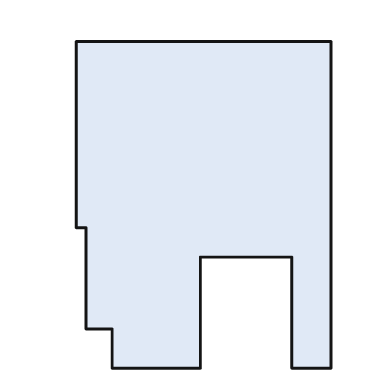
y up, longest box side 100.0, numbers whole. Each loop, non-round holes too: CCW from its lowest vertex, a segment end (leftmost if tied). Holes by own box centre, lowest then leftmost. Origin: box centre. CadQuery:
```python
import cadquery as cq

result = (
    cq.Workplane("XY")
    .moveTo(-28.0, -50.0)
    .lineTo(-1.0, -50.0)
    .lineTo(-1.0, -16.0)
    .lineTo(27.0, -16.0)
    .lineTo(27.0, -50.0)
    .lineTo(39.0, -50.0)
    .lineTo(39.0, 50.0)
    .lineTo(-39.0, 50.0)
    .lineTo(-39.0, -7.0)
    .lineTo(-36.0, -7.0)
    .lineTo(-36.0, -38.0)
    .lineTo(-28.0, -38.0)
    .close()
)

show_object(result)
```